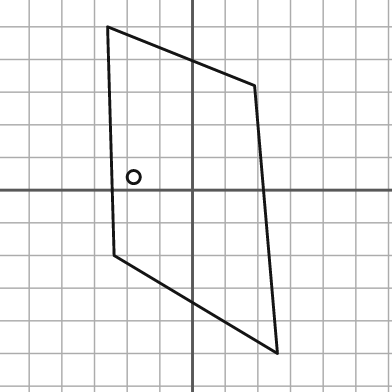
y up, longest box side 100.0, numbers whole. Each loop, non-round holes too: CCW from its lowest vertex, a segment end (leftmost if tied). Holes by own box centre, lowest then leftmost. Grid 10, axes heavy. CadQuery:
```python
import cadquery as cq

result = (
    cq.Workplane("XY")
    .moveTo(26.0, -50.0)
    .lineTo(19.0, 32.0)
    .lineTo(-26.0, 50.0)
    .lineTo(-24.0, -20.0)
    .close()
    .moveTo(-18.0, 4.0)
    .circle(2.0)
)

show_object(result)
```